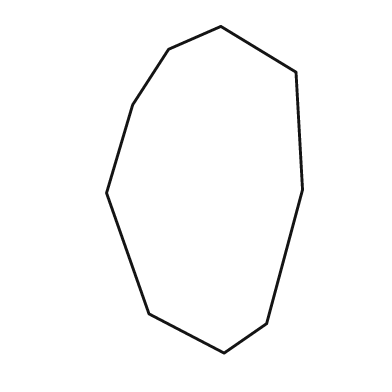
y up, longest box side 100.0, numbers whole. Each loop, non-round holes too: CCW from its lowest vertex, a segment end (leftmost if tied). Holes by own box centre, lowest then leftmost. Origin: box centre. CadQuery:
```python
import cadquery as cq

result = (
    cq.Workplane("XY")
    .moveTo(6.0, -50.0)
    .lineTo(19.0, -41.0)
    .lineTo(30.0, 0.0)
    .lineTo(28.0, 36.0)
    .lineTo(5.0, 50.0)
    .lineTo(-11.0, 43.0)
    .lineTo(-22.0, 26.0)
    .lineTo(-30.0, -1.0)
    .lineTo(-17.0, -38.0)
    .close()
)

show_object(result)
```